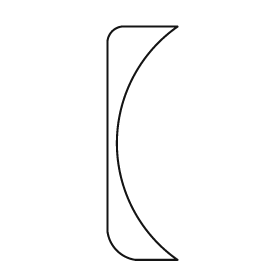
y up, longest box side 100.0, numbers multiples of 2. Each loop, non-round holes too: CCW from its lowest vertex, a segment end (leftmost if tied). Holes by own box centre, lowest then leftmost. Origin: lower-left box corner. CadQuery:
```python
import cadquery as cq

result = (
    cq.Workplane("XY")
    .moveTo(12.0, 0.0)
    .lineTo(30.0, 0.0)
    .threePointArc((4.0, 50.0), (30.0, 100.0))
    .lineTo(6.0, 100.0)
    .threePointArc((2.0, 98.0), (0.0, 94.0))
    .lineTo(0.0, 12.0)
    .threePointArc((4.0, 4.0), (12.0, 0.0))
    .close()
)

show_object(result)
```